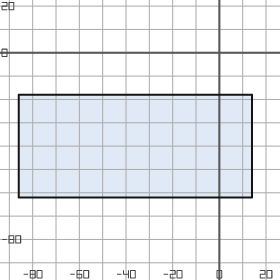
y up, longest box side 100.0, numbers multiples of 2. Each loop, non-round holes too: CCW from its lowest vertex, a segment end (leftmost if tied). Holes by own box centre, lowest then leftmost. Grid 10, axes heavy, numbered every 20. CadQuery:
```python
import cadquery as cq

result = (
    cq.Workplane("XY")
    .moveTo(-86.0, -62.0)
    .lineTo(14.0, -62.0)
    .lineTo(14.0, -18.0)
    .lineTo(-86.0, -18.0)
    .close()
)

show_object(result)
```